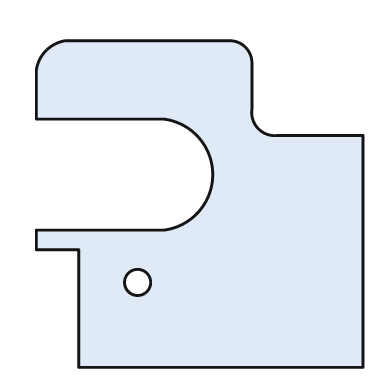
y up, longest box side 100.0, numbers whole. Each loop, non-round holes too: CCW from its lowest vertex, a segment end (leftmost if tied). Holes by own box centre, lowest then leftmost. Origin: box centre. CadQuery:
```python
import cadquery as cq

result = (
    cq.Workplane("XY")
    .moveTo(-37.0, -50.0)
    .lineTo(50.0, -50.0)
    .lineTo(50.0, 21.0)
    .lineTo(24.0, 21.0)
    .threePointArc((18.0, 23.0), (16.0, 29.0))
    .lineTo(16.0, 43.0)
    .threePointArc((14.0, 48.0), (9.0, 50.0))
    .lineTo(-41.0, 50.0)
    .threePointArc((-47.0, 47.0), (-50.0, 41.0))
    .lineTo(-50.0, 26.0)
    .lineTo(-11.0, 26.0)
    .threePointArc((4.0, 9.0), (-11.0, -8.0))
    .lineTo(-50.0, -8.0)
    .lineTo(-50.0, -14.0)
    .lineTo(-37.0, -14.0)
    .close()
    .moveTo(-19.0, -24.0)
    .circle(4.0)
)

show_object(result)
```